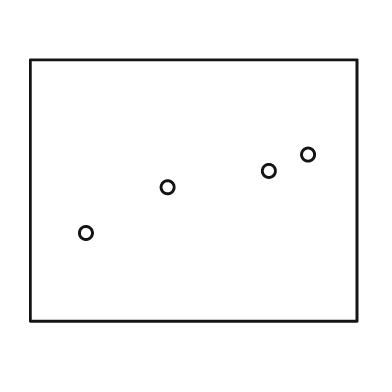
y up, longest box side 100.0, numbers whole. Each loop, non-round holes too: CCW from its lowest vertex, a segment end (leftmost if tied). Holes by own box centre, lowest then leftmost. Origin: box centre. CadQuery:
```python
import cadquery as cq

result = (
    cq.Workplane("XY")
    .moveTo(-50.0, -40.0)
    .lineTo(50.0, -40.0)
    .lineTo(50.0, 40.0)
    .lineTo(-50.0, 40.0)
    .close()
    .moveTo(-33.0, -13.0)
    .circle(2.0)
    .moveTo(-8.0, 1.0)
    .circle(2.0)
    .moveTo(23.0, 6.0)
    .circle(2.0)
    .moveTo(35.0, 11.0)
    .circle(2.0)
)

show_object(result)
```